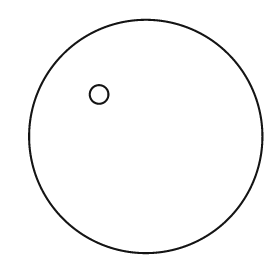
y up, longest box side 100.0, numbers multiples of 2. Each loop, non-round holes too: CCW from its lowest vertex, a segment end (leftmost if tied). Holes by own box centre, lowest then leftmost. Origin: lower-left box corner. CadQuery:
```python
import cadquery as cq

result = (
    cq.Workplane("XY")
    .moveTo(50.0, 50.0)
    .circle(50.0)
    .moveTo(30.0, 68.0)
    .circle(4.0)
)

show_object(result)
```